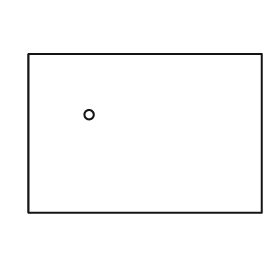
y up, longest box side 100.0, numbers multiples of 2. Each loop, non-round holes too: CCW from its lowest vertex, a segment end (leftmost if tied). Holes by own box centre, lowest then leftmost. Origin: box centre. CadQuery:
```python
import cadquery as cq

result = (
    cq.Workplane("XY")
    .moveTo(-50.0, -34.0)
    .lineTo(50.0, -34.0)
    .lineTo(50.0, 34.0)
    .lineTo(-50.0, 34.0)
    .close()
    .moveTo(-24.0, 8.0)
    .circle(2.0)
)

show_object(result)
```